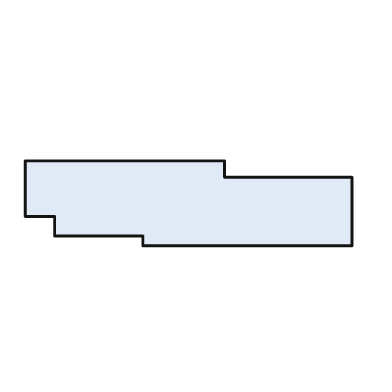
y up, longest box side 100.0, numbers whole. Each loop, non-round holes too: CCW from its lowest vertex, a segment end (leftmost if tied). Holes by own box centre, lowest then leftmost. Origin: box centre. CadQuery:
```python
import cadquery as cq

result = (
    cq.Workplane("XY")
    .moveTo(-14.0, -13.0)
    .lineTo(50.0, -13.0)
    .lineTo(50.0, 8.0)
    .lineTo(11.0, 8.0)
    .lineTo(11.0, 13.0)
    .lineTo(-50.0, 13.0)
    .lineTo(-50.0, -4.0)
    .lineTo(-41.0, -4.0)
    .lineTo(-41.0, -10.0)
    .lineTo(-14.0, -10.0)
    .close()
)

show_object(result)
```